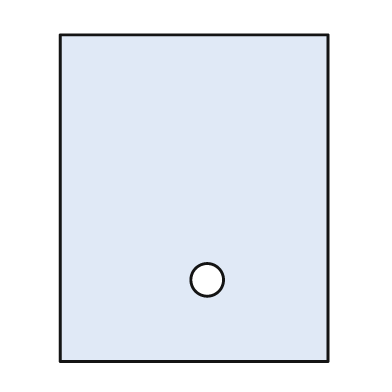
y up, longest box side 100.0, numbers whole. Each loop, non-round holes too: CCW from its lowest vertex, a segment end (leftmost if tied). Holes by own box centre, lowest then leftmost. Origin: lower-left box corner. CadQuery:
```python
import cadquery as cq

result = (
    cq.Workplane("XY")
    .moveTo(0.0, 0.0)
    .lineTo(82.0, 0.0)
    .lineTo(82.0, 100.0)
    .lineTo(0.0, 100.0)
    .close()
    .moveTo(45.0, 25.0)
    .circle(5.0)
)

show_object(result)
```